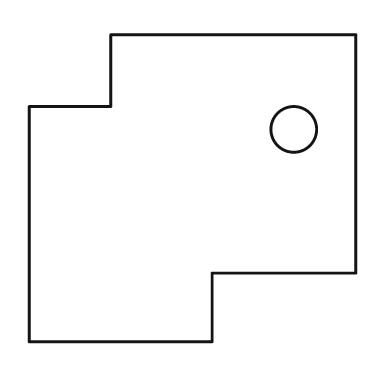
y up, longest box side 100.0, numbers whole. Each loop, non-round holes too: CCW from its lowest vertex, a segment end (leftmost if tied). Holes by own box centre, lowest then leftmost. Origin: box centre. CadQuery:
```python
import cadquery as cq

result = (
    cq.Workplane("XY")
    .moveTo(-50.0, -47.0)
    .lineTo(6.0, -47.0)
    .lineTo(6.0, -26.0)
    .lineTo(50.0, -26.0)
    .lineTo(50.0, 47.0)
    .lineTo(-25.0, 47.0)
    .lineTo(-25.0, 25.0)
    .lineTo(-50.0, 25.0)
    .close()
    .moveTo(31.0, 18.0)
    .circle(7.0)
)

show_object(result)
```